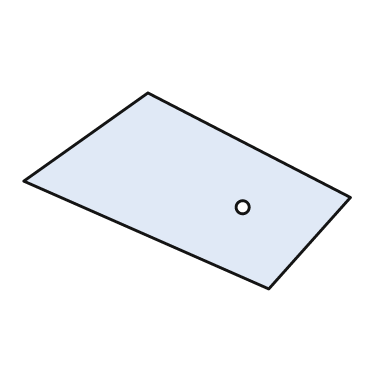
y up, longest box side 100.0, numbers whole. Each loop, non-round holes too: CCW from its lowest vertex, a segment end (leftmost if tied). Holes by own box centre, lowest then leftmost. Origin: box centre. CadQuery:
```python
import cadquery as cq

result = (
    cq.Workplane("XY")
    .moveTo(25.0, -30.0)
    .lineTo(50.0, -2.0)
    .lineTo(-12.0, 30.0)
    .lineTo(-50.0, 3.0)
    .close()
    .moveTo(17.0, -5.0)
    .circle(2.0)
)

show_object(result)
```